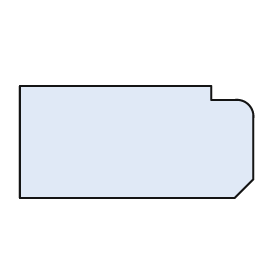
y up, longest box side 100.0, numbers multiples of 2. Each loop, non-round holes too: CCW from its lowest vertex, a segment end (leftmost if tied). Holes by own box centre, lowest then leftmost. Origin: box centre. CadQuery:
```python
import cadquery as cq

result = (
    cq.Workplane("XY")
    .moveTo(-50.0, -24.0)
    .lineTo(42.0, -24.0)
    .lineTo(50.0, -16.0)
    .lineTo(50.0, 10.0)
    .threePointArc((48.0, 16.0), (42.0, 18.0))
    .lineTo(32.0, 18.0)
    .lineTo(32.0, 24.0)
    .lineTo(-50.0, 24.0)
    .close()
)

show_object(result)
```